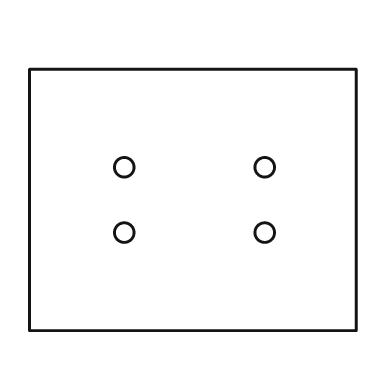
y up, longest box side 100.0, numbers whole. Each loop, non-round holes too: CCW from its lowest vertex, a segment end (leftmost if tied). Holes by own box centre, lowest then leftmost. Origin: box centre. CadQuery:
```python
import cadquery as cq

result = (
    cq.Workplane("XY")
    .moveTo(-50.0, -40.0)
    .lineTo(50.0, -40.0)
    .lineTo(50.0, 40.0)
    .lineTo(-50.0, 40.0)
    .close()
    .moveTo(-21.0, -10.0)
    .circle(3.0)
    .moveTo(22.0, -10.0)
    .circle(3.0)
    .moveTo(-21.0, 10.0)
    .circle(3.0)
    .moveTo(22.0, 10.0)
    .circle(3.0)
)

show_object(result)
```